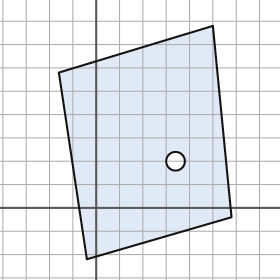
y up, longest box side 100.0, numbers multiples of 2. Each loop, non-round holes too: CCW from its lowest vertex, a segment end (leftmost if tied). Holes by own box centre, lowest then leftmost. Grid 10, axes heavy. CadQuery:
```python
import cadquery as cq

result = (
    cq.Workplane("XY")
    .moveTo(-4.0, -22.0)
    .lineTo(58.0, -4.0)
    .lineTo(50.0, 78.0)
    .lineTo(-16.0, 58.0)
    .close()
    .moveTo(34.0, 20.0)
    .circle(4.0)
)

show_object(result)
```